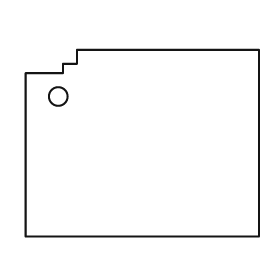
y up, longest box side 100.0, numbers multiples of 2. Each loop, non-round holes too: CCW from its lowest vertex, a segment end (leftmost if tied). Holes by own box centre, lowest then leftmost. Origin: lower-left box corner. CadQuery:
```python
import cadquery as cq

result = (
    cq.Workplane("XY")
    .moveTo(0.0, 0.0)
    .lineTo(100.0, 0.0)
    .lineTo(100.0, 80.0)
    .lineTo(22.0, 80.0)
    .lineTo(22.0, 74.0)
    .lineTo(16.0, 74.0)
    .lineTo(16.0, 70.0)
    .lineTo(0.0, 70.0)
    .close()
    .moveTo(14.0, 60.0)
    .circle(4.0)
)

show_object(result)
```